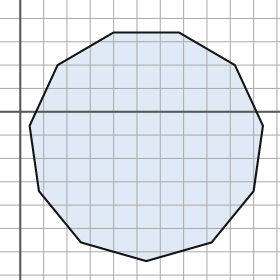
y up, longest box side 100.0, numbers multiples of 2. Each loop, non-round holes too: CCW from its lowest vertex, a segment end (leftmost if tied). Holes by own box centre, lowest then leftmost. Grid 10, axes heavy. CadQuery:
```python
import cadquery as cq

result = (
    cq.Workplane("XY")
    .moveTo(54.0, -64.0)
    .lineTo(82.0, -56.0)
    .lineTo(100.0, -34.0)
    .lineTo(104.0, -6.0)
    .lineTo(92.0, 20.0)
    .lineTo(68.0, 34.0)
    .lineTo(40.0, 34.0)
    .lineTo(16.0, 20.0)
    .lineTo(4.0, -6.0)
    .lineTo(8.0, -34.0)
    .lineTo(26.0, -56.0)
    .close()
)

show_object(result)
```